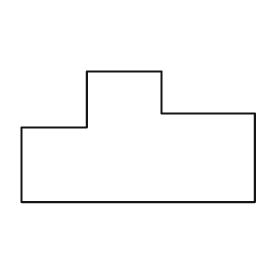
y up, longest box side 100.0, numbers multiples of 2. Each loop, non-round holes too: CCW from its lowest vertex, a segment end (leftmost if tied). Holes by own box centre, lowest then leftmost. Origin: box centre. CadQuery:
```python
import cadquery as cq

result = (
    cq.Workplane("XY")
    .moveTo(-50.0, -28.0)
    .lineTo(50.0, -28.0)
    .lineTo(50.0, 10.0)
    .lineTo(10.0, 10.0)
    .lineTo(10.0, 28.0)
    .lineTo(-22.0, 28.0)
    .lineTo(-22.0, 4.0)
    .lineTo(-50.0, 4.0)
    .close()
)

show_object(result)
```